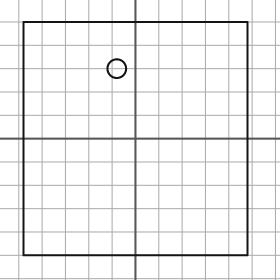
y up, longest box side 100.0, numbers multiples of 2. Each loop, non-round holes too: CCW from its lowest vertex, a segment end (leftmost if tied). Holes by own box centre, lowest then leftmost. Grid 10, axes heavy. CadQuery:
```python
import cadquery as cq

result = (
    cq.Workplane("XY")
    .moveTo(-48.0, -50.0)
    .lineTo(48.0, -50.0)
    .lineTo(48.0, 50.0)
    .lineTo(-48.0, 50.0)
    .close()
    .moveTo(-8.0, 30.0)
    .circle(4.0)
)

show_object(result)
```